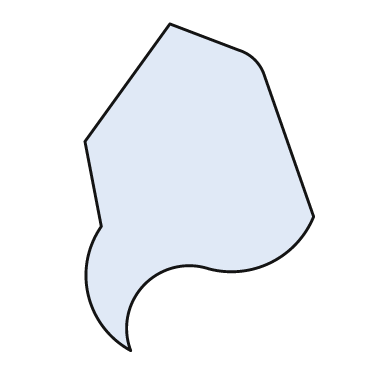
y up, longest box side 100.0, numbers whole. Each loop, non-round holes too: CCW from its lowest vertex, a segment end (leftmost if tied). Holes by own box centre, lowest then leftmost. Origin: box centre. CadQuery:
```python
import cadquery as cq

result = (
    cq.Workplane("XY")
    .moveTo(-21.0, -50.0)
    .threePointArc((-17.0, -30.0), (3.0, -25.0))
    .threePointArc((22.0, -23.0), (35.0, -9.0))
    .lineTo(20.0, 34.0)
    .threePointArc((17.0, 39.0), (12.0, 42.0))
    .lineTo(-9.0, 50.0)
    .lineTo(-35.0, 14.0)
    .lineTo(-30.0, -12.0)
    .threePointArc((-34.0, -33.0), (-21.0, -50.0))
    .close()
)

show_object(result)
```